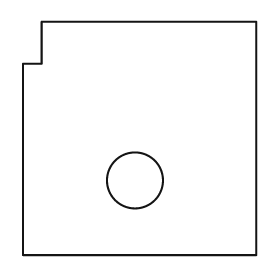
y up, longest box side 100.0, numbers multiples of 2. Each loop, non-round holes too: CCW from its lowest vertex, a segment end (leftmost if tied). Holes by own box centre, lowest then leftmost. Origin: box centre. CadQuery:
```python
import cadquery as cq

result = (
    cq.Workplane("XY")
    .moveTo(-50.0, -50.0)
    .lineTo(50.0, -50.0)
    .lineTo(50.0, 50.0)
    .lineTo(-42.0, 50.0)
    .lineTo(-42.0, 32.0)
    .lineTo(-50.0, 32.0)
    .close()
    .moveTo(-2.0, -18.0)
    .circle(12.0)
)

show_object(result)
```